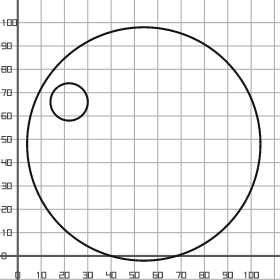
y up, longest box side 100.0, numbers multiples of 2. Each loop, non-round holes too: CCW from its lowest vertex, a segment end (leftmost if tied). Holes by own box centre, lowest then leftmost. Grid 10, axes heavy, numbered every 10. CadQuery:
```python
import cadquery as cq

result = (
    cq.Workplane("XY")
    .moveTo(54.0, 48.0)
    .circle(50.0)
    .moveTo(22.0, 66.0)
    .circle(8.0)
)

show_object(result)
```